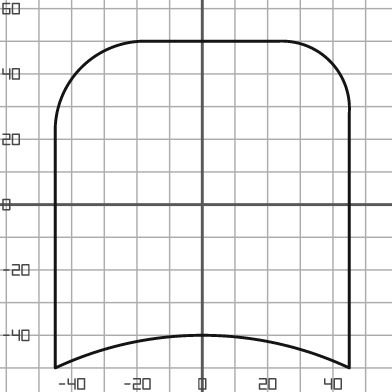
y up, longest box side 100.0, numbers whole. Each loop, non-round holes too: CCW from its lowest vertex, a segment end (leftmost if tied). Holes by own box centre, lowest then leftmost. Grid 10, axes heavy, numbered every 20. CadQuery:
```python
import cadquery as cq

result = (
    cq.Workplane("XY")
    .moveTo(-45.0, -50.0)
    .threePointArc((0.0, -40.0), (45.0, -50.0))
    .lineTo(45.0, 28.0)
    .threePointArc((39.0, 44.0), (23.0, 50.0))
    .lineTo(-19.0, 50.0)
    .threePointArc((-37.0, 42.0), (-45.0, 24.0))
    .close()
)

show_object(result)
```